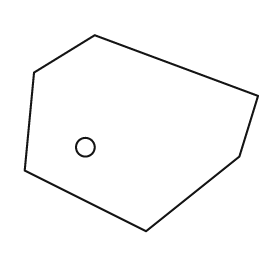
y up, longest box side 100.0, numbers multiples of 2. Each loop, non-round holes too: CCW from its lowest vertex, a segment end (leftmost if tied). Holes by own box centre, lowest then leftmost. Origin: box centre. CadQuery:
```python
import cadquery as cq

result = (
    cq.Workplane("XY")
    .moveTo(2.0, -42.0)
    .lineTo(42.0, -10.0)
    .lineTo(50.0, 16.0)
    .lineTo(-20.0, 42.0)
    .lineTo(-46.0, 26.0)
    .lineTo(-50.0, -16.0)
    .close()
    .moveTo(-24.0, -6.0)
    .circle(4.0)
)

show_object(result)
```